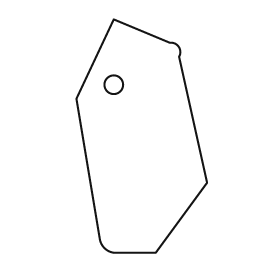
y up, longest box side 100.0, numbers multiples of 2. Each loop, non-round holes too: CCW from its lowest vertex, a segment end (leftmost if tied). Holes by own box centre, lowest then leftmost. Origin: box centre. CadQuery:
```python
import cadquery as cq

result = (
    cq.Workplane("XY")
    .moveTo(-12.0, -50.0)
    .lineTo(6.0, -50.0)
    .lineTo(28.0, -20.0)
    .lineTo(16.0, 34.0)
    .threePointArc((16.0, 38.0), (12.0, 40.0))
    .lineTo(-12.0, 50.0)
    .lineTo(-28.0, 16.0)
    .lineTo(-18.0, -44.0)
    .threePointArc((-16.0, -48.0), (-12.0, -50.0))
    .close()
    .moveTo(-12.0, 22.0)
    .circle(4.0)
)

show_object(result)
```